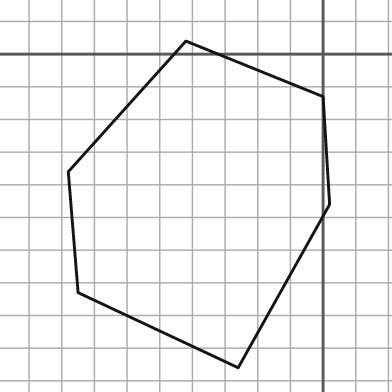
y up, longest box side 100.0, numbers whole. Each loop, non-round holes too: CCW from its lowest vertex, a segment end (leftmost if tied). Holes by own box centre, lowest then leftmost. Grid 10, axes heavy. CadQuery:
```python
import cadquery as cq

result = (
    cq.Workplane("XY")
    .moveTo(-26.0, -96.0)
    .lineTo(2.0, -46.0)
    .lineTo(0.0, -13.0)
    .lineTo(-42.0, 4.0)
    .lineTo(-78.0, -36.0)
    .lineTo(-75.0, -73.0)
    .close()
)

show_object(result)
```